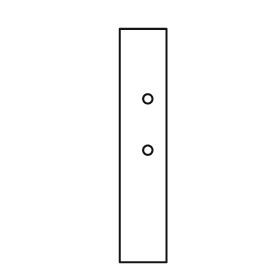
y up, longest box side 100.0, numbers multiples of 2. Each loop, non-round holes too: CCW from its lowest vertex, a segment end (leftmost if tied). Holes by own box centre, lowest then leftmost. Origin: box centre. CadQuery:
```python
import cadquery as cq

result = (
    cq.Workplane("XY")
    .moveTo(-10.0, -50.0)
    .lineTo(10.0, -50.0)
    .lineTo(10.0, 50.0)
    .lineTo(-10.0, 50.0)
    .close()
    .moveTo(2.0, -2.0)
    .circle(2.0)
    .moveTo(2.0, 20.0)
    .circle(2.0)
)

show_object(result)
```